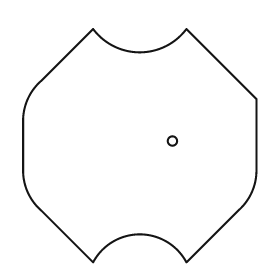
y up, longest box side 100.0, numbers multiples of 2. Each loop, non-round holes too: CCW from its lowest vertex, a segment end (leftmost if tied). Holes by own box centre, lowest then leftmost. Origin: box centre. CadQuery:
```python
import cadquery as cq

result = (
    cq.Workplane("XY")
    .moveTo(-20.0, -50.0)
    .threePointArc((0.0, -38.0), (20.0, -50.0))
    .lineTo(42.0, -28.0)
    .threePointArc((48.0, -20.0), (50.0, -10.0))
    .lineTo(50.0, 20.0)
    .lineTo(20.0, 50.0)
    .threePointArc((0.0, 40.0), (-20.0, 50.0))
    .lineTo(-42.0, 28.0)
    .threePointArc((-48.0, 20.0), (-50.0, 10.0))
    .lineTo(-50.0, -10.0)
    .threePointArc((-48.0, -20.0), (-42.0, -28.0))
    .close()
    .moveTo(14.0, 2.0)
    .circle(2.0)
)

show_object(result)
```